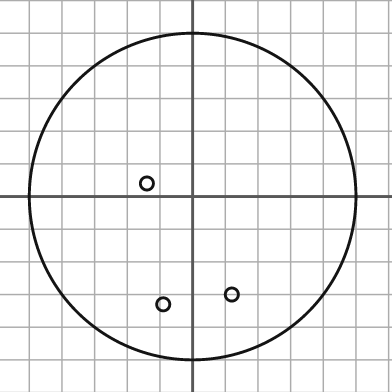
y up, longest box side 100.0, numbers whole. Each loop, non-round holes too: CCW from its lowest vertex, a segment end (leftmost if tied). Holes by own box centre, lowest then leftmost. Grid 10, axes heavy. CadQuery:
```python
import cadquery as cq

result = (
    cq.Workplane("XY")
    .moveTo(0.0, 0.0)
    .circle(50.0)
    .moveTo(-9.0, -33.0)
    .circle(2.0)
    .moveTo(12.0, -30.0)
    .circle(2.0)
    .moveTo(-14.0, 4.0)
    .circle(2.0)
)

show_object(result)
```